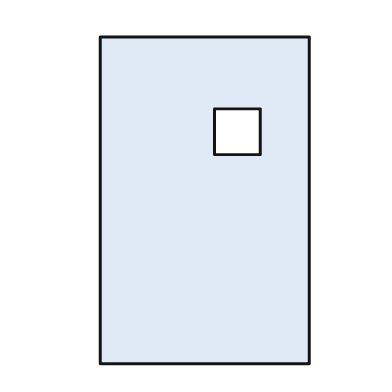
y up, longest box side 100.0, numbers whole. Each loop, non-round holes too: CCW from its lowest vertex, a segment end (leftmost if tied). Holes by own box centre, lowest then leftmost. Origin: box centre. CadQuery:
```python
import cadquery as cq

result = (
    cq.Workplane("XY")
    .moveTo(-32.0, -50.0)
    .lineTo(32.0, -50.0)
    .lineTo(32.0, 50.0)
    .lineTo(-32.0, 50.0)
    .close()
    .moveTo(3.0, 14.0)
    .lineTo(17.0, 14.0)
    .lineTo(17.0, 28.0)
    .lineTo(3.0, 28.0)
    .close()
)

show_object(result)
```